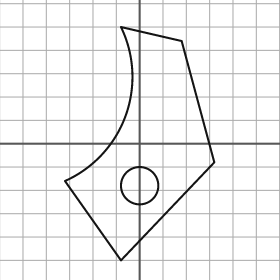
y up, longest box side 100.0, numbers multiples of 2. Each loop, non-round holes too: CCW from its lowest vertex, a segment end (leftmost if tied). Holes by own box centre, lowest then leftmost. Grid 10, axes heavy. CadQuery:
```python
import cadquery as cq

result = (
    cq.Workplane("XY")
    .moveTo(-8.0, -50.0)
    .lineTo(32.0, -8.0)
    .lineTo(18.0, 44.0)
    .lineTo(-8.0, 50.0)
    .threePointArc((-6.0, 12.0), (-32.0, -16.0))
    .close()
    .moveTo(0.0, -18.0)
    .circle(8.0)
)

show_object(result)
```